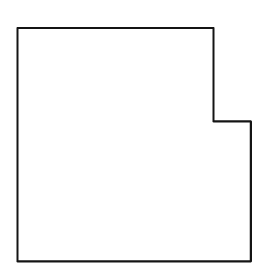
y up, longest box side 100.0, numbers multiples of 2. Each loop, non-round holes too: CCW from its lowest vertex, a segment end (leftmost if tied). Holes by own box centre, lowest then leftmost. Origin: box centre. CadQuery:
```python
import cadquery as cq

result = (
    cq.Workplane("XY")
    .moveTo(-50.0, -50.0)
    .lineTo(50.0, -50.0)
    .lineTo(50.0, 10.0)
    .lineTo(34.0, 10.0)
    .lineTo(34.0, 50.0)
    .lineTo(-50.0, 50.0)
    .close()
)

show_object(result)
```